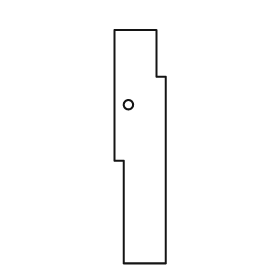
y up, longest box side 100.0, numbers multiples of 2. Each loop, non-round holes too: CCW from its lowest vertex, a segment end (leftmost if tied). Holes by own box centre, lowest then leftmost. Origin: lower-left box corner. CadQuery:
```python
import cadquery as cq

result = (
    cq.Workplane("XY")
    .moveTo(4.0, 0.0)
    .lineTo(22.0, 0.0)
    .lineTo(22.0, 80.0)
    .lineTo(18.0, 80.0)
    .lineTo(18.0, 100.0)
    .lineTo(0.0, 100.0)
    .lineTo(0.0, 44.0)
    .lineTo(4.0, 44.0)
    .close()
    .moveTo(6.0, 68.0)
    .circle(2.0)
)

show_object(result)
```